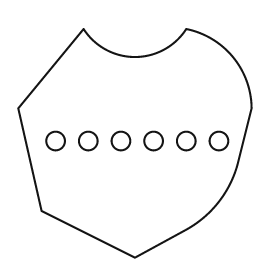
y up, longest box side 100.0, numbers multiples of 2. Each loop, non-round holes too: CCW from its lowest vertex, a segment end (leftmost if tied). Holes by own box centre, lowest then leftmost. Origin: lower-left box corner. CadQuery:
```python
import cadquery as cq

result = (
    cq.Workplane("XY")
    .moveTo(50.0, 0.0)
    .lineTo(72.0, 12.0)
    .threePointArc((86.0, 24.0), (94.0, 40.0))
    .lineTo(100.0, 64.0)
    .threePointArc((92.0, 86.0), (72.0, 98.0))
    .threePointArc((50.0, 86.0), (28.0, 98.0))
    .lineTo(0.0, 64.0)
    .lineTo(10.0, 20.0)
    .close()
    .moveTo(16.0, 50.0)
    .circle(4.0)
    .moveTo(30.0, 50.0)
    .circle(4.0)
    .moveTo(44.0, 50.0)
    .circle(4.0)
    .moveTo(58.0, 50.0)
    .circle(4.0)
    .moveTo(72.0, 50.0)
    .circle(4.0)
    .moveTo(86.0, 50.0)
    .circle(4.0)
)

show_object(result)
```